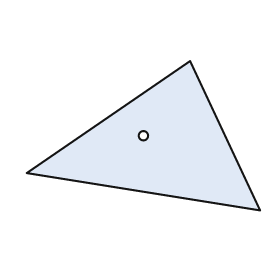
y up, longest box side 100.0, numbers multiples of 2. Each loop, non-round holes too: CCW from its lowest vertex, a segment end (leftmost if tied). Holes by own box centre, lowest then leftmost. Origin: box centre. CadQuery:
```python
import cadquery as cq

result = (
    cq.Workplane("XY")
    .moveTo(50.0, -32.0)
    .lineTo(20.0, 32.0)
    .lineTo(-50.0, -16.0)
    .close()
    .moveTo(0.0, 0.0)
    .circle(2.0)
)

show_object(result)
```